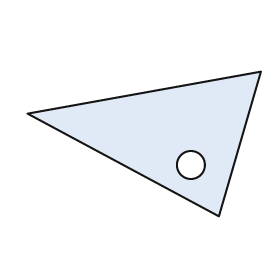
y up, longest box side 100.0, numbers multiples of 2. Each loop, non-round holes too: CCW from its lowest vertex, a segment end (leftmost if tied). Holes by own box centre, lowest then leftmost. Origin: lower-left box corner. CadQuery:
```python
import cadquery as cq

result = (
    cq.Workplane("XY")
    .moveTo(82.0, 0.0)
    .lineTo(100.0, 62.0)
    .lineTo(0.0, 44.0)
    .close()
    .moveTo(70.0, 22.0)
    .circle(6.0)
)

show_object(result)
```